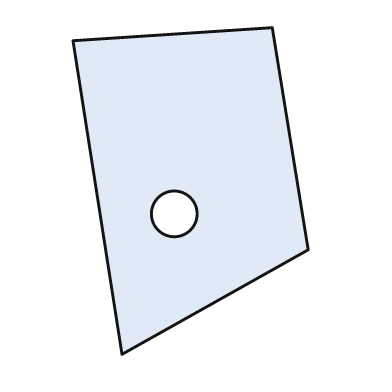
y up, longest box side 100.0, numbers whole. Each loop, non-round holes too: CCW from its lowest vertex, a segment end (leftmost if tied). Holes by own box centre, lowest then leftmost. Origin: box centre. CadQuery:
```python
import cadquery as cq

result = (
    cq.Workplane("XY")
    .moveTo(-21.0, -50.0)
    .lineTo(36.0, -18.0)
    .lineTo(25.0, 50.0)
    .lineTo(-36.0, 46.0)
    .close()
    .moveTo(-5.0, -7.0)
    .circle(7.0)
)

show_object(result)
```